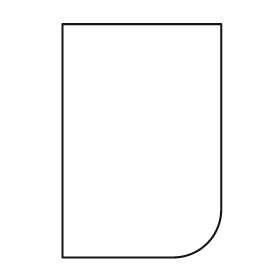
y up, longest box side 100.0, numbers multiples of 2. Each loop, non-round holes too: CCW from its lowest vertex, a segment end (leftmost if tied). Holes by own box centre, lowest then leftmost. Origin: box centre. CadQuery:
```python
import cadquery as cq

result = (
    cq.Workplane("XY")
    .moveTo(-34.0, -50.0)
    .lineTo(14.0, -50.0)
    .threePointArc((28.0, -44.0), (34.0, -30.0))
    .lineTo(34.0, 50.0)
    .lineTo(-34.0, 50.0)
    .close()
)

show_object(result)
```